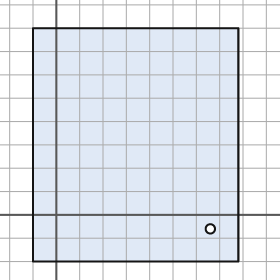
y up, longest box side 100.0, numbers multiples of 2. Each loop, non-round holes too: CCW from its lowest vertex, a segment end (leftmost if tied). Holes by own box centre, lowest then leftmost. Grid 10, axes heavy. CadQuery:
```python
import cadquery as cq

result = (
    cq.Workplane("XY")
    .moveTo(-10.0, -20.0)
    .lineTo(78.0, -20.0)
    .lineTo(78.0, 80.0)
    .lineTo(-10.0, 80.0)
    .close()
    .moveTo(66.0, -6.0)
    .circle(2.0)
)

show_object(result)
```